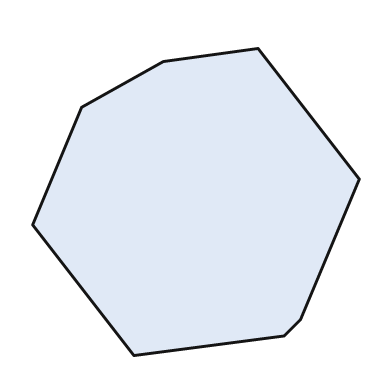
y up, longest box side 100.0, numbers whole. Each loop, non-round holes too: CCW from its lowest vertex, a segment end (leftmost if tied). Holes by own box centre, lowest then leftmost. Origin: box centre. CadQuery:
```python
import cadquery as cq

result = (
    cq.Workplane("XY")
    .moveTo(-19.0, -47.0)
    .lineTo(27.0, -41.0)
    .lineTo(32.0, -36.0)
    .lineTo(50.0, 7.0)
    .lineTo(19.0, 47.0)
    .lineTo(-10.0, 43.0)
    .lineTo(-35.0, 29.0)
    .lineTo(-50.0, -7.0)
    .close()
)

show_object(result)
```